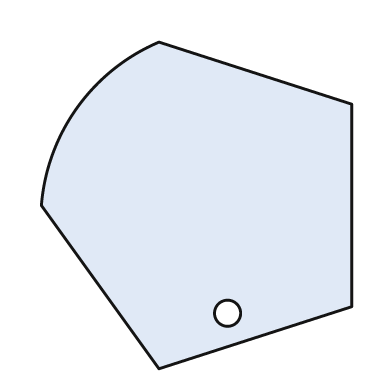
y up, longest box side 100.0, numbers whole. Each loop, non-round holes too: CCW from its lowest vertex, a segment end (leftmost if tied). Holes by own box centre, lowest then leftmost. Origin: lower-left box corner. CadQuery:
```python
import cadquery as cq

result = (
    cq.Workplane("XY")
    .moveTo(36.0, 0.0)
    .lineTo(95.0, 19.0)
    .lineTo(95.0, 81.0)
    .lineTo(36.0, 100.0)
    .threePointArc((11.0, 80.0), (0.0, 50.0))
    .close()
    .moveTo(57.0, 17.0)
    .circle(4.0)
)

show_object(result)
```